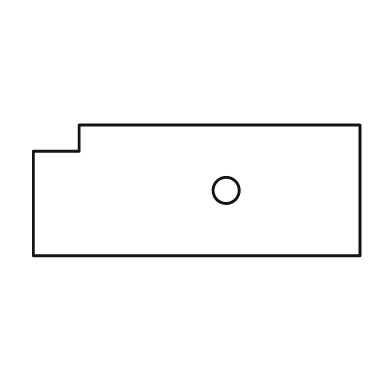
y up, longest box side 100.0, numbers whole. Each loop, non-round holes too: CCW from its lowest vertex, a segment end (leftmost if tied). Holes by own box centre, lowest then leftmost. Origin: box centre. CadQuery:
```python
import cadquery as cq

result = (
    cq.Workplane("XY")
    .moveTo(-50.0, -20.0)
    .lineTo(50.0, -20.0)
    .lineTo(50.0, 20.0)
    .lineTo(-36.0, 20.0)
    .lineTo(-36.0, 12.0)
    .lineTo(-50.0, 12.0)
    .close()
    .moveTo(9.0, 0.0)
    .circle(4.0)
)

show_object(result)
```